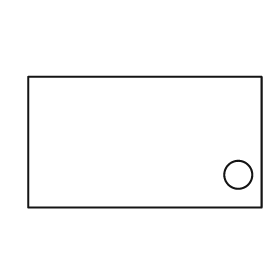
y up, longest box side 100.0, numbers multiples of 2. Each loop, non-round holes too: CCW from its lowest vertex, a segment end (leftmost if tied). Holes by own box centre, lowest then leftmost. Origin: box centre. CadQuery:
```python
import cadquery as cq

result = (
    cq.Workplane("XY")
    .moveTo(-50.0, -28.0)
    .lineTo(50.0, -28.0)
    .lineTo(50.0, 28.0)
    .lineTo(-50.0, 28.0)
    .close()
    .moveTo(40.0, -14.0)
    .circle(6.0)
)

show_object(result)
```